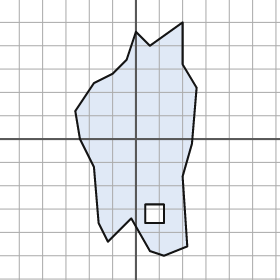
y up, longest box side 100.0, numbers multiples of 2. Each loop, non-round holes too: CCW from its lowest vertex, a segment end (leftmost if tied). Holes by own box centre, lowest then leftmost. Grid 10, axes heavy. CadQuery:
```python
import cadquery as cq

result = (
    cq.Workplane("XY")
    .moveTo(12.0, -50.0)
    .lineTo(22.0, -46.0)
    .lineTo(20.0, -16.0)
    .lineTo(24.0, -2.0)
    .lineTo(26.0, 22.0)
    .lineTo(20.0, 32.0)
    .lineTo(20.0, 50.0)
    .lineTo(6.0, 40.0)
    .lineTo(0.0, 46.0)
    .lineTo(-4.0, 34.0)
    .lineTo(-10.0, 28.0)
    .lineTo(-18.0, 24.0)
    .lineTo(-26.0, 12.0)
    .lineTo(-24.0, 0.0)
    .lineTo(-18.0, -12.0)
    .lineTo(-16.0, -36.0)
    .lineTo(-12.0, -44.0)
    .lineTo(-2.0, -34.0)
    .lineTo(6.0, -48.0)
    .close()
    .moveTo(4.0, -36.0)
    .lineTo(12.0, -36.0)
    .lineTo(12.0, -28.0)
    .lineTo(4.0, -28.0)
    .close()
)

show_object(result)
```